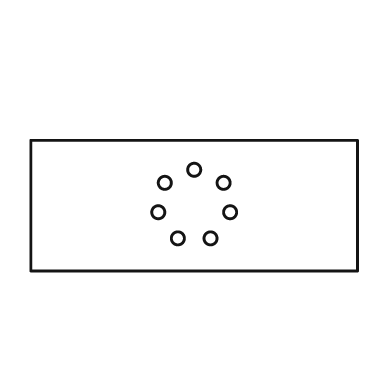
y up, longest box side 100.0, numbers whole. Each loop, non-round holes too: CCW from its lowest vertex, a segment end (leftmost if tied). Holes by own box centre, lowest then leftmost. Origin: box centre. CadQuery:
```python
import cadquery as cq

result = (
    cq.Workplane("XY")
    .moveTo(-50.0, -20.0)
    .lineTo(50.0, -20.0)
    .lineTo(50.0, 20.0)
    .lineTo(-50.0, 20.0)
    .close()
    .moveTo(-5.0, -10.0)
    .circle(2.0)
    .moveTo(5.0, -10.0)
    .circle(2.0)
    .moveTo(-11.0, -2.0)
    .circle(2.0)
    .moveTo(11.0, -2.0)
    .circle(2.0)
    .moveTo(-9.0, 7.0)
    .circle(2.0)
    .moveTo(9.0, 7.0)
    .circle(2.0)
    .moveTo(0.0, 11.0)
    .circle(2.0)
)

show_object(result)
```